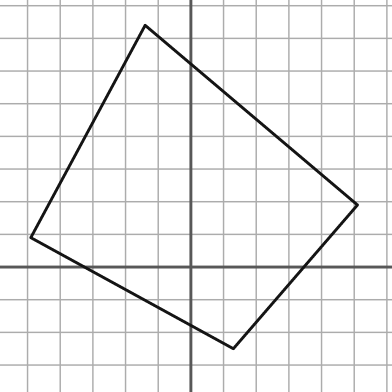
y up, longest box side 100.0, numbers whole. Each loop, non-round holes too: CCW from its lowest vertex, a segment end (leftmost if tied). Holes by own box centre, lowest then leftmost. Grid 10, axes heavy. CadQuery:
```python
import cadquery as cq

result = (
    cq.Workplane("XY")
    .moveTo(13.0, -25.0)
    .lineTo(51.0, 19.0)
    .lineTo(-14.0, 74.0)
    .lineTo(-49.0, 9.0)
    .close()
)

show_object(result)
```